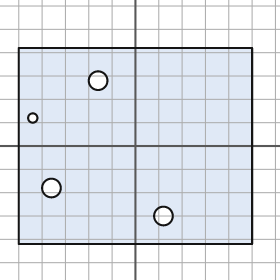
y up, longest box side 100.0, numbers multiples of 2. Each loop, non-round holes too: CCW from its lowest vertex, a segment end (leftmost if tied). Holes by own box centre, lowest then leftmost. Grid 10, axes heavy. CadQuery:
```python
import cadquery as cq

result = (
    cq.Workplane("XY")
    .moveTo(-50.0, -42.0)
    .lineTo(50.0, -42.0)
    .lineTo(50.0, 42.0)
    .lineTo(-50.0, 42.0)
    .close()
    .moveTo(12.0, -30.0)
    .circle(4.0)
    .moveTo(-36.0, -18.0)
    .circle(4.0)
    .moveTo(-44.0, 12.0)
    .circle(2.0)
    .moveTo(-16.0, 28.0)
    .circle(4.0)
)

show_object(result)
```